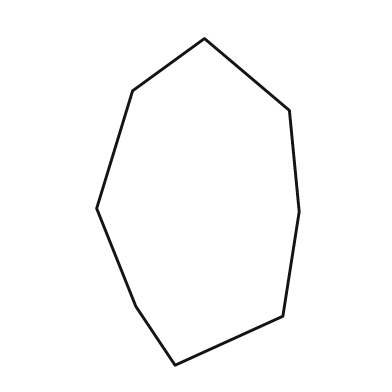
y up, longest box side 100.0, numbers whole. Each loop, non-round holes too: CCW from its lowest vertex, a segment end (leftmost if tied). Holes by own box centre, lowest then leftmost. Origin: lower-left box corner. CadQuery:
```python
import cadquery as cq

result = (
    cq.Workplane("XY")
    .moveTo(24.0, 0.0)
    .lineTo(57.0, 15.0)
    .lineTo(62.0, 47.0)
    .lineTo(59.0, 78.0)
    .lineTo(33.0, 100.0)
    .lineTo(11.0, 84.0)
    .lineTo(0.0, 48.0)
    .lineTo(12.0, 18.0)
    .close()
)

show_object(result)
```